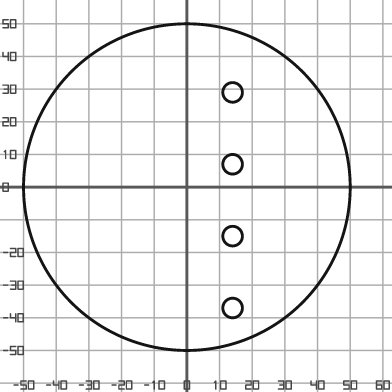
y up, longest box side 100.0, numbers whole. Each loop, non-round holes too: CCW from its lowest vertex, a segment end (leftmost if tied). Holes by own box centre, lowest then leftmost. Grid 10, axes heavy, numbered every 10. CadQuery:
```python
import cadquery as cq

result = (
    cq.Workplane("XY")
    .moveTo(0.0, 0.0)
    .circle(50.0)
    .moveTo(14.0, -37.0)
    .circle(3.0)
    .moveTo(14.0, -15.0)
    .circle(3.0)
    .moveTo(14.0, 7.0)
    .circle(3.0)
    .moveTo(14.0, 29.0)
    .circle(3.0)
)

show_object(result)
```